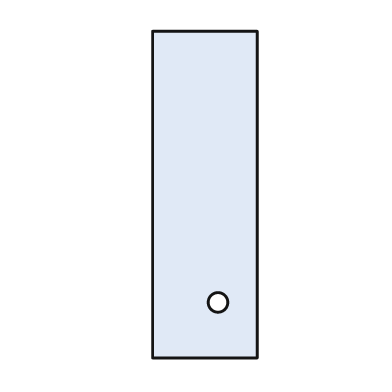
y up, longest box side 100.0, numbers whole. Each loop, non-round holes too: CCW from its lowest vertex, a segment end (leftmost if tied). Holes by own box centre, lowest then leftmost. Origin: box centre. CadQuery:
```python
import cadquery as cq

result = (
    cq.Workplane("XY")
    .moveTo(-16.0, -50.0)
    .lineTo(16.0, -50.0)
    .lineTo(16.0, 50.0)
    .lineTo(-16.0, 50.0)
    .close()
    .moveTo(4.0, -33.0)
    .circle(3.0)
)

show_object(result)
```